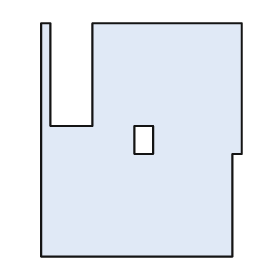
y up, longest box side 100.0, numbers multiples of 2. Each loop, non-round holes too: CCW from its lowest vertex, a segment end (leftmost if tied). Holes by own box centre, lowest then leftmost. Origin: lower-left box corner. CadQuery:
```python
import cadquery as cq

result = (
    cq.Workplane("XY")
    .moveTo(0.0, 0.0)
    .lineTo(82.0, 0.0)
    .lineTo(82.0, 44.0)
    .lineTo(86.0, 44.0)
    .lineTo(86.0, 100.0)
    .lineTo(22.0, 100.0)
    .lineTo(22.0, 56.0)
    .lineTo(4.0, 56.0)
    .lineTo(4.0, 100.0)
    .lineTo(0.0, 100.0)
    .close()
    .moveTo(40.0, 44.0)
    .lineTo(48.0, 44.0)
    .lineTo(48.0, 56.0)
    .lineTo(40.0, 56.0)
    .close()
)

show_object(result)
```